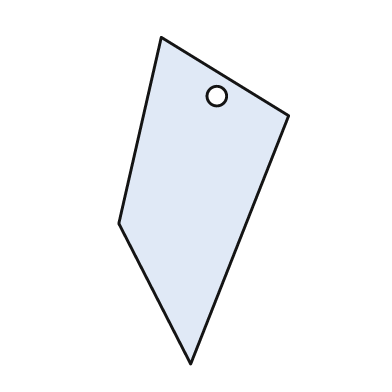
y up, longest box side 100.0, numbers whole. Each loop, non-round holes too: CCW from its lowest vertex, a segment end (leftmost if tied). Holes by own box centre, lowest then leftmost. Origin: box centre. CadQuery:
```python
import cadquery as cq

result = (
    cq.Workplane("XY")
    .moveTo(-4.0, -50.0)
    .lineTo(26.0, 26.0)
    .lineTo(-13.0, 50.0)
    .lineTo(-26.0, -7.0)
    .close()
    .moveTo(4.0, 32.0)
    .circle(3.0)
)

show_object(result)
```